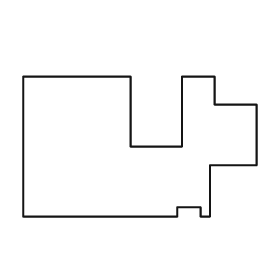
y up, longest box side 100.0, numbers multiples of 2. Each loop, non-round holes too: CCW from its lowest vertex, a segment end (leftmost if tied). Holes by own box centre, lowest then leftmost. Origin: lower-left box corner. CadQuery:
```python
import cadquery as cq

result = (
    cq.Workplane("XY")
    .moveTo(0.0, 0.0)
    .lineTo(66.0, 0.0)
    .lineTo(66.0, 4.0)
    .lineTo(76.0, 4.0)
    .lineTo(76.0, 0.0)
    .lineTo(80.0, 0.0)
    .lineTo(80.0, 22.0)
    .lineTo(100.0, 22.0)
    .lineTo(100.0, 48.0)
    .lineTo(82.0, 48.0)
    .lineTo(82.0, 60.0)
    .lineTo(68.0, 60.0)
    .lineTo(68.0, 30.0)
    .lineTo(46.0, 30.0)
    .lineTo(46.0, 60.0)
    .lineTo(0.0, 60.0)
    .close()
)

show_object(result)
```